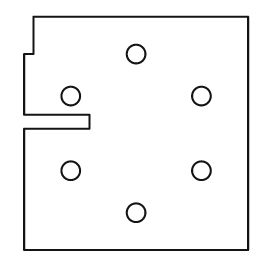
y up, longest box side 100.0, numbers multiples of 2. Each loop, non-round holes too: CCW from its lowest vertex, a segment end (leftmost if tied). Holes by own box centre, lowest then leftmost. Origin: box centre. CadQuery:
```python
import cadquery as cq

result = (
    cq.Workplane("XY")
    .moveTo(-48.0, -50.0)
    .lineTo(48.0, -50.0)
    .lineTo(48.0, 50.0)
    .lineTo(-44.0, 50.0)
    .lineTo(-44.0, 34.0)
    .lineTo(-48.0, 34.0)
    .lineTo(-48.0, 8.0)
    .lineTo(-20.0, 8.0)
    .lineTo(-20.0, 2.0)
    .lineTo(-48.0, 2.0)
    .close()
    .moveTo(0.0, -34.0)
    .circle(4.0)
    .moveTo(-28.0, -16.0)
    .circle(4.0)
    .moveTo(28.0, -16.0)
    .circle(4.0)
    .moveTo(-28.0, 16.0)
    .circle(4.0)
    .moveTo(28.0, 16.0)
    .circle(4.0)
    .moveTo(0.0, 34.0)
    .circle(4.0)
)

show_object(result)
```